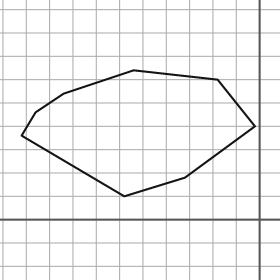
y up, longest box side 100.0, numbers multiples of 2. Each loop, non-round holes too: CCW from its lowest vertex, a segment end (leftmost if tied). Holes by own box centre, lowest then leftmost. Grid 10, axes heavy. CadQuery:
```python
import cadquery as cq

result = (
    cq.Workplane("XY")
    .moveTo(-58.0, 10.0)
    .lineTo(-32.0, 18.0)
    .lineTo(-2.0, 40.0)
    .lineTo(-18.0, 60.0)
    .lineTo(-54.0, 64.0)
    .lineTo(-84.0, 54.0)
    .lineTo(-96.0, 46.0)
    .lineTo(-102.0, 36.0)
    .close()
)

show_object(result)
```